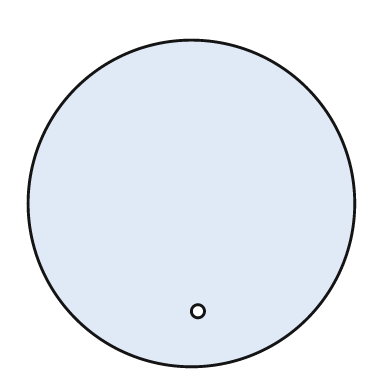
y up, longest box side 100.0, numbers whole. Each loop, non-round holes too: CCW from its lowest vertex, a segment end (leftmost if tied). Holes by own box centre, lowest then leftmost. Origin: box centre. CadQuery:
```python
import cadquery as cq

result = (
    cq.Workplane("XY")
    .moveTo(0.0, 0.0)
    .circle(50.0)
    .moveTo(2.0, -33.0)
    .circle(2.0)
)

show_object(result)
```